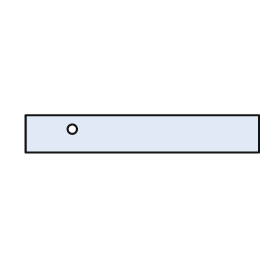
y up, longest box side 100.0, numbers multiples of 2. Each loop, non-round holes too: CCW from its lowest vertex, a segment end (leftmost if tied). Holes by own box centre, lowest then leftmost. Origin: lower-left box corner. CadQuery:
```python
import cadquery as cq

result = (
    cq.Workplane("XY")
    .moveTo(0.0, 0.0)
    .lineTo(100.0, 0.0)
    .lineTo(100.0, 16.0)
    .lineTo(0.0, 16.0)
    .close()
    .moveTo(20.0, 10.0)
    .circle(2.0)
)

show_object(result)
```